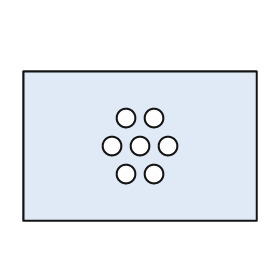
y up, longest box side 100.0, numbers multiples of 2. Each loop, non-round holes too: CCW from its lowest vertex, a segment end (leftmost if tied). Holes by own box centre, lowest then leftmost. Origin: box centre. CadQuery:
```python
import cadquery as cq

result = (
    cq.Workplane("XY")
    .moveTo(-50.0, -32.0)
    .lineTo(50.0, -32.0)
    .lineTo(50.0, 32.0)
    .lineTo(-50.0, 32.0)
    .close()
    .moveTo(-6.0, -12.0)
    .circle(4.0)
    .moveTo(6.0, -12.0)
    .circle(4.0)
    .moveTo(-12.0, 0.0)
    .circle(4.0)
    .moveTo(0.0, 0.0)
    .circle(4.0)
    .moveTo(12.0, 0.0)
    .circle(4.0)
    .moveTo(-6.0, 12.0)
    .circle(4.0)
    .moveTo(6.0, 12.0)
    .circle(4.0)
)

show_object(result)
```